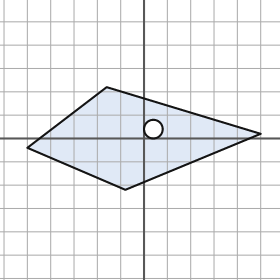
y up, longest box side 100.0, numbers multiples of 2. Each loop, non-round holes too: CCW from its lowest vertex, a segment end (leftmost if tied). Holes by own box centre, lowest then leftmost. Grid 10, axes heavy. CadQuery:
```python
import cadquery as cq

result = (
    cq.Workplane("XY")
    .moveTo(-8.0, -22.0)
    .lineTo(50.0, 2.0)
    .lineTo(-16.0, 22.0)
    .lineTo(-50.0, -4.0)
    .close()
    .moveTo(4.0, 4.0)
    .circle(4.0)
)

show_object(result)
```